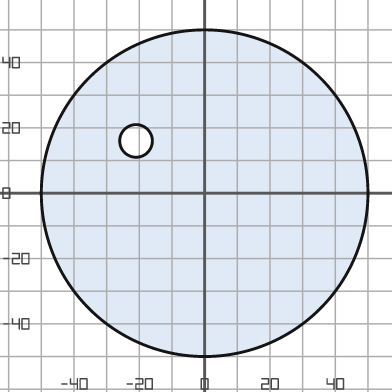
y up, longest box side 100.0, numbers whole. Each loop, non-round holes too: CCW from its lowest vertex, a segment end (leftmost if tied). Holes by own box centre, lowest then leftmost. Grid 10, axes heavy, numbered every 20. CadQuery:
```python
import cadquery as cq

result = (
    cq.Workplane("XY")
    .moveTo(0.0, 0.0)
    .circle(50.0)
    .moveTo(-21.0, 16.0)
    .circle(5.0)
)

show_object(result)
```